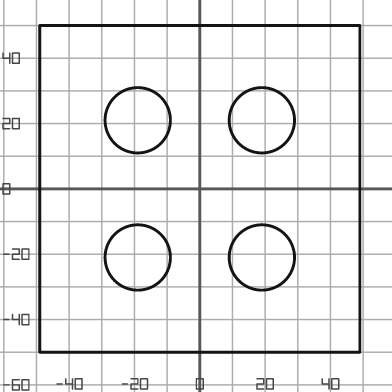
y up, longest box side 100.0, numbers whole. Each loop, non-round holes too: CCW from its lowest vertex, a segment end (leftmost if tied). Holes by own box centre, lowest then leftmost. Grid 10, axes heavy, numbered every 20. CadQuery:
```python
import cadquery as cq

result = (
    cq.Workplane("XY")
    .moveTo(-49.0, -50.0)
    .lineTo(49.0, -50.0)
    .lineTo(49.0, 50.0)
    .lineTo(-49.0, 50.0)
    .close()
    .moveTo(-19.0, -21.0)
    .circle(10.0)
    .moveTo(19.0, -21.0)
    .circle(10.0)
    .moveTo(-19.0, 21.0)
    .circle(10.0)
    .moveTo(19.0, 21.0)
    .circle(10.0)
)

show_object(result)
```